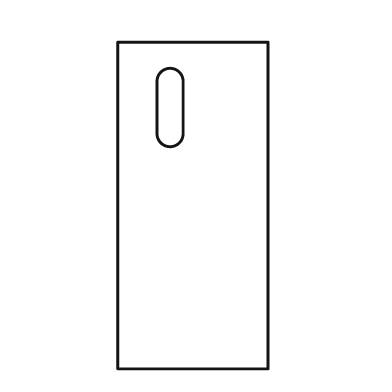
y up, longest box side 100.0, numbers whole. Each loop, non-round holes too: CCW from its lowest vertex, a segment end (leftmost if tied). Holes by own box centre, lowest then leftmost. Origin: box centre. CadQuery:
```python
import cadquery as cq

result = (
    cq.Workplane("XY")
    .moveTo(-23.0, -50.0)
    .lineTo(23.0, -50.0)
    .lineTo(23.0, 50.0)
    .lineTo(-23.0, 50.0)
    .close()
    .moveTo(-11.0, 22.0)
    .threePointArc((-7.0, 18.0), (-3.0, 22.0))
    .lineTo(-3.0, 38.0)
    .threePointArc((-7.0, 42.0), (-11.0, 38.0))
    .close()
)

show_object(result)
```